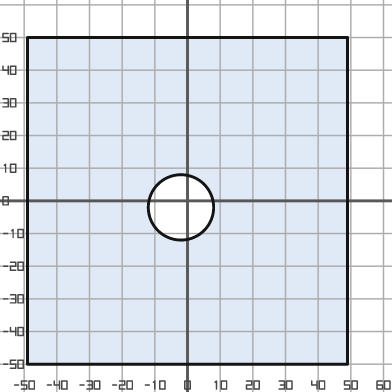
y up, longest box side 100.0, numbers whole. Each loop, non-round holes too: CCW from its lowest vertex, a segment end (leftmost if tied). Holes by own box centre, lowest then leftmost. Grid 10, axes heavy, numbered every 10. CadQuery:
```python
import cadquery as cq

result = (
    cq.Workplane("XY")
    .moveTo(-49.0, -50.0)
    .lineTo(49.0, -50.0)
    .lineTo(49.0, 50.0)
    .lineTo(-49.0, 50.0)
    .close()
    .moveTo(-2.0, -2.0)
    .circle(10.0)
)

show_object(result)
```